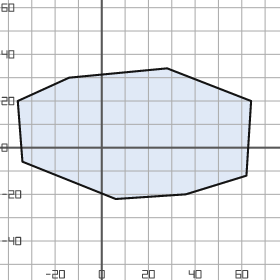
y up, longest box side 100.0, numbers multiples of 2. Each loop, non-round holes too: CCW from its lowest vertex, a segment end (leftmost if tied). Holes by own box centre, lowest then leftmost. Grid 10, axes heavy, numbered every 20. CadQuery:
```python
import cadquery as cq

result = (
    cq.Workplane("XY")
    .moveTo(6.0, -22.0)
    .lineTo(36.0, -20.0)
    .lineTo(62.0, -12.0)
    .lineTo(64.0, 20.0)
    .lineTo(28.0, 34.0)
    .lineTo(-14.0, 30.0)
    .lineTo(-36.0, 20.0)
    .lineTo(-34.0, -6.0)
    .close()
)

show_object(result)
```